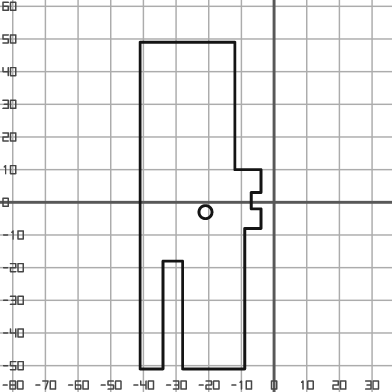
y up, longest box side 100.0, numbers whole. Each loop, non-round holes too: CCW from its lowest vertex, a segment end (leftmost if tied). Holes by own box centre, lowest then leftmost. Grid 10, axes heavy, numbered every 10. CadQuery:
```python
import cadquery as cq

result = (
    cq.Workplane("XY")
    .moveTo(-41.0, -51.0)
    .lineTo(-34.0, -51.0)
    .lineTo(-34.0, -18.0)
    .lineTo(-28.0, -18.0)
    .lineTo(-28.0, -51.0)
    .lineTo(-9.0, -51.0)
    .lineTo(-9.0, -8.0)
    .lineTo(-4.0, -8.0)
    .lineTo(-4.0, -2.0)
    .lineTo(-7.0, -2.0)
    .lineTo(-7.0, 3.0)
    .lineTo(-4.0, 3.0)
    .lineTo(-4.0, 10.0)
    .lineTo(-12.0, 10.0)
    .lineTo(-12.0, 49.0)
    .lineTo(-41.0, 49.0)
    .close()
    .moveTo(-21.0, -3.0)
    .circle(2.0)
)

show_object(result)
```